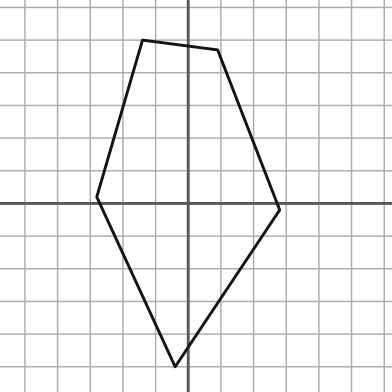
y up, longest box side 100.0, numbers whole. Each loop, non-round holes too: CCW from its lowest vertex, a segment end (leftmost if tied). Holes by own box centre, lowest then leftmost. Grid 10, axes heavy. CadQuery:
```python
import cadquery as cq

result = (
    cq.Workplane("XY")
    .moveTo(-4.0, -50.0)
    .lineTo(28.0, -2.0)
    .lineTo(9.0, 47.0)
    .lineTo(-14.0, 50.0)
    .lineTo(-28.0, 2.0)
    .close()
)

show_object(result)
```